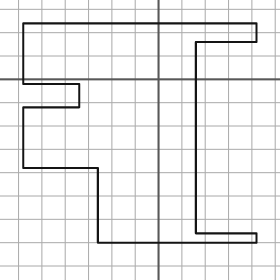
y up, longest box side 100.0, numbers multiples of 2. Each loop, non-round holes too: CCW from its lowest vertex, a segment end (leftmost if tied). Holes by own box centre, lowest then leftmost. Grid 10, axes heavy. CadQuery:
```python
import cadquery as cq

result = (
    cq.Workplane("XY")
    .moveTo(-26.0, -70.0)
    .lineTo(42.0, -70.0)
    .lineTo(42.0, -66.0)
    .lineTo(16.0, -66.0)
    .lineTo(16.0, 16.0)
    .lineTo(42.0, 16.0)
    .lineTo(42.0, 24.0)
    .lineTo(-58.0, 24.0)
    .lineTo(-58.0, -2.0)
    .lineTo(-34.0, -2.0)
    .lineTo(-34.0, -12.0)
    .lineTo(-58.0, -12.0)
    .lineTo(-58.0, -38.0)
    .lineTo(-26.0, -38.0)
    .close()
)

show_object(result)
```